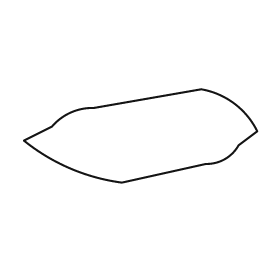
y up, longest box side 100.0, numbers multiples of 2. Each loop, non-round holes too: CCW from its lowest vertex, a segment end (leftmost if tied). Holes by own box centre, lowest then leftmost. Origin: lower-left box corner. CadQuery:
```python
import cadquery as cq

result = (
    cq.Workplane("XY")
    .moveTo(42.0, 0.0)
    .lineTo(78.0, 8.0)
    .threePointArc((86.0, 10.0), (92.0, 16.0))
    .lineTo(100.0, 22.0)
    .threePointArc((90.0, 34.0), (76.0, 40.0))
    .lineTo(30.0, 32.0)
    .threePointArc((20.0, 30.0), (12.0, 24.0))
    .lineTo(0.0, 18.0)
    .threePointArc((20.0, 6.0), (42.0, 0.0))
    .close()
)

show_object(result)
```